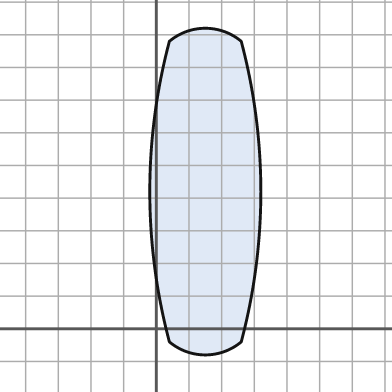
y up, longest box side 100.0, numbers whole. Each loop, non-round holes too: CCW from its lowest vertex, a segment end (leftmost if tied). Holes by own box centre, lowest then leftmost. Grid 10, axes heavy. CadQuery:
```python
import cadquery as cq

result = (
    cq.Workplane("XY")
    .moveTo(4.0, -4.0)
    .threePointArc((15.0, -8.0), (26.0, -4.0))
    .threePointArc((32.0, 42.0), (26.0, 88.0))
    .threePointArc((15.0, 92.0), (4.0, 88.0))
    .threePointArc((-2.0, 42.0), (4.0, -4.0))
    .close()
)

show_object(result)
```